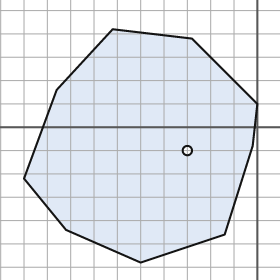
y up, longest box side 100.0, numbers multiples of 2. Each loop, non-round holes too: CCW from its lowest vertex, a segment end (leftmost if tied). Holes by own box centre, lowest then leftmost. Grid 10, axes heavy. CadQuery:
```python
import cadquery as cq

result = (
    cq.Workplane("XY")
    .moveTo(-50.0, -58.0)
    .lineTo(-14.0, -46.0)
    .lineTo(-2.0, -8.0)
    .lineTo(0.0, 10.0)
    .lineTo(-28.0, 38.0)
    .lineTo(-62.0, 42.0)
    .lineTo(-86.0, 16.0)
    .lineTo(-100.0, -22.0)
    .lineTo(-82.0, -44.0)
    .close()
    .moveTo(-30.0, -10.0)
    .circle(2.0)
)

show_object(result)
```